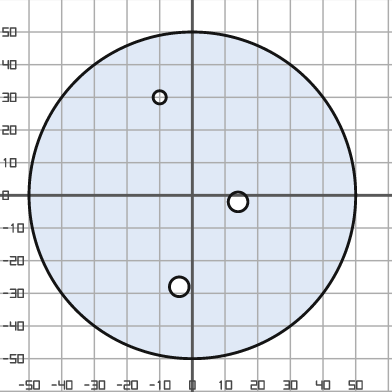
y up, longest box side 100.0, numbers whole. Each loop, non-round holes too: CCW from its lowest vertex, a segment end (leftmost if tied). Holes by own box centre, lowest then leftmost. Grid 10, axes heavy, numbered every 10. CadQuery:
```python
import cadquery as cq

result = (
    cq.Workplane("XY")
    .moveTo(0.0, 0.0)
    .circle(50.0)
    .moveTo(-4.0, -28.0)
    .circle(3.0)
    .moveTo(14.0, -2.0)
    .circle(3.0)
    .moveTo(-10.0, 30.0)
    .circle(2.0)
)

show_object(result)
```